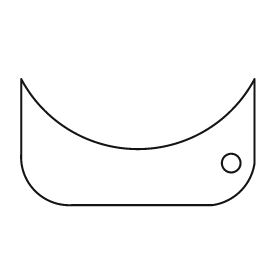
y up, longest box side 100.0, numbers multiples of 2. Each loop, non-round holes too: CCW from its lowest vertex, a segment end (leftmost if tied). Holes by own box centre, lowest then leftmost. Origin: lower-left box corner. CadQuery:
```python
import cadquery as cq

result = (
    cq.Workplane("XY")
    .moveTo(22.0, 0.0)
    .lineTo(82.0, 0.0)
    .threePointArc((94.0, 6.0), (100.0, 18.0))
    .lineTo(100.0, 54.0)
    .threePointArc((50.0, 24.0), (0.0, 54.0))
    .lineTo(0.0, 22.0)
    .threePointArc((6.0, 6.0), (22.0, 0.0))
    .close()
    .moveTo(90.0, 18.0)
    .circle(4.0)
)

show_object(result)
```